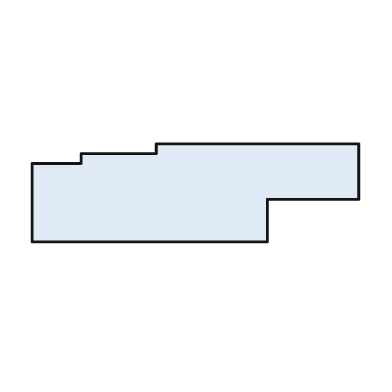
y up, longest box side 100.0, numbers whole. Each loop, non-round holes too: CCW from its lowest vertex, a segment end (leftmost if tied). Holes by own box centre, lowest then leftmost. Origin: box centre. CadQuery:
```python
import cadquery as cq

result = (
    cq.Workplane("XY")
    .moveTo(-50.0, -15.0)
    .lineTo(22.0, -15.0)
    .lineTo(22.0, -2.0)
    .lineTo(50.0, -2.0)
    .lineTo(50.0, 15.0)
    .lineTo(-12.0, 15.0)
    .lineTo(-12.0, 12.0)
    .lineTo(-35.0, 12.0)
    .lineTo(-35.0, 9.0)
    .lineTo(-50.0, 9.0)
    .close()
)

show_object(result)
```